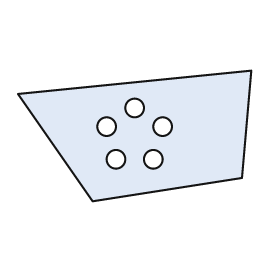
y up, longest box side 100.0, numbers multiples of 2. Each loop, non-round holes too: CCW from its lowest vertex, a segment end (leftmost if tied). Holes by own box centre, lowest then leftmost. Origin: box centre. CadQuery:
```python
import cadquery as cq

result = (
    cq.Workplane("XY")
    .moveTo(-18.0, -28.0)
    .lineTo(46.0, -18.0)
    .lineTo(50.0, 28.0)
    .lineTo(-50.0, 18.0)
    .close()
    .moveTo(-8.0, -10.0)
    .circle(4.0)
    .moveTo(8.0, -10.0)
    .circle(4.0)
    .moveTo(-12.0, 4.0)
    .circle(4.0)
    .moveTo(12.0, 4.0)
    .circle(4.0)
    .moveTo(0.0, 12.0)
    .circle(4.0)
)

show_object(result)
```